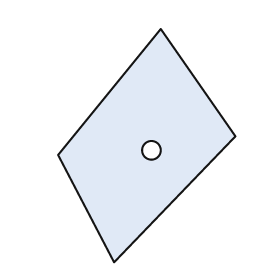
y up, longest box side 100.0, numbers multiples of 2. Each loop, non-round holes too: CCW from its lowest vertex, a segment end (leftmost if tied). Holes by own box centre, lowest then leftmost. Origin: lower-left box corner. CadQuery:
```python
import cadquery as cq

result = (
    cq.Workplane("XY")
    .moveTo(24.0, 0.0)
    .lineTo(76.0, 54.0)
    .lineTo(44.0, 100.0)
    .lineTo(0.0, 46.0)
    .close()
    .moveTo(40.0, 48.0)
    .circle(4.0)
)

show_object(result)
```